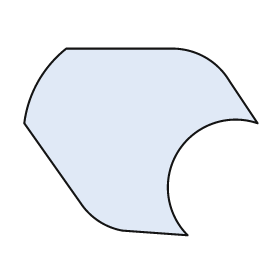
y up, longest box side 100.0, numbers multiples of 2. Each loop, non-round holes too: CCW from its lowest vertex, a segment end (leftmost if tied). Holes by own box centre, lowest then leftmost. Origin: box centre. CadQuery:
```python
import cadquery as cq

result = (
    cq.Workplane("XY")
    .moveTo(20.0, -40.0)
    .threePointArc((16.0, -4.0), (50.0, 8.0))
    .lineTo(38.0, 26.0)
    .threePointArc((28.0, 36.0), (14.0, 40.0))
    .lineTo(-32.0, 40.0)
    .threePointArc((-44.0, 26.0), (-50.0, 8.0))
    .lineTo(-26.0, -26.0)
    .threePointArc((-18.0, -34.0), (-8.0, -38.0))
    .close()
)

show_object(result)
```